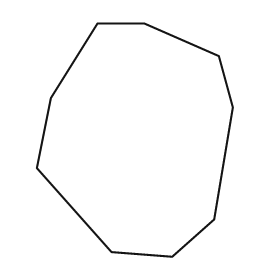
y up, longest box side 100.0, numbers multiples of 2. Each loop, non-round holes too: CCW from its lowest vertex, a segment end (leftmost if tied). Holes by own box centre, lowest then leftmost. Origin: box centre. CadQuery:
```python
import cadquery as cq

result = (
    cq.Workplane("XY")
    .moveTo(16.0, -50.0)
    .lineTo(34.0, -34.0)
    .lineTo(42.0, 14.0)
    .lineTo(36.0, 36.0)
    .lineTo(4.0, 50.0)
    .lineTo(-16.0, 50.0)
    .lineTo(-36.0, 18.0)
    .lineTo(-42.0, -12.0)
    .lineTo(-10.0, -48.0)
    .close()
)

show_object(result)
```